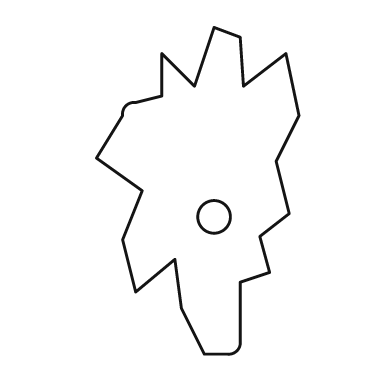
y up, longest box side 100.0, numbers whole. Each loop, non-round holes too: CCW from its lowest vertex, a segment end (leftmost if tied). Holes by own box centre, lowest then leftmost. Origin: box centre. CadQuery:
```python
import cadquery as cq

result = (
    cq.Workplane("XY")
    .moveTo(2.0, -50.0)
    .lineTo(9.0, -50.0)
    .threePointArc((12.0, -49.0), (13.0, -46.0))
    .lineTo(13.0, -28.0)
    .lineTo(22.0, -25.0)
    .lineTo(19.0, -14.0)
    .lineTo(28.0, -7.0)
    .lineTo(24.0, 9.0)
    .lineTo(31.0, 23.0)
    .lineTo(27.0, 42.0)
    .lineTo(14.0, 32.0)
    .lineTo(13.0, 47.0)
    .lineTo(5.0, 50.0)
    .lineTo(-1.0, 32.0)
    .lineTo(-11.0, 42.0)
    .lineTo(-11.0, 29.0)
    .lineTo(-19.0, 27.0)
    .threePointArc((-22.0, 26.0), (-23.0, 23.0))
    .lineTo(-31.0, 10.0)
    .lineTo(-17.0, 0.0)
    .lineTo(-23.0, -15.0)
    .lineTo(-19.0, -31.0)
    .lineTo(-7.0, -21.0)
    .lineTo(-5.0, -36.0)
    .close()
    .moveTo(5.0, -8.0)
    .circle(5.0)
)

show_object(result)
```